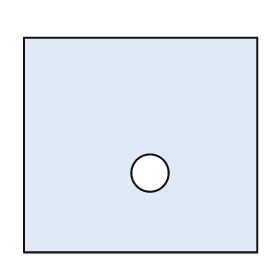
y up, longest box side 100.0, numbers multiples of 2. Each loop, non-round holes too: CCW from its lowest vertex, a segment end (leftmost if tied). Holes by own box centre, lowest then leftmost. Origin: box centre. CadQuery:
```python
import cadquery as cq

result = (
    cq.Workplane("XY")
    .moveTo(-50.0, -46.0)
    .lineTo(50.0, -46.0)
    .lineTo(50.0, 46.0)
    .lineTo(-50.0, 46.0)
    .close()
    .moveTo(4.0, -12.0)
    .circle(8.0)
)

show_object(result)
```